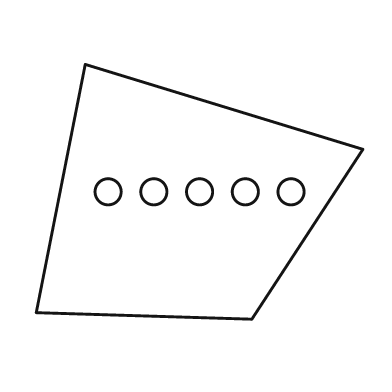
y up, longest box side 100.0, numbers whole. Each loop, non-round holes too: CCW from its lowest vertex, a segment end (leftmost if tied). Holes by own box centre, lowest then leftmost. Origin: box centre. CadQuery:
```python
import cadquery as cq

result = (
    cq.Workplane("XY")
    .moveTo(16.0, -39.0)
    .lineTo(50.0, 13.0)
    .lineTo(-35.0, 39.0)
    .lineTo(-50.0, -37.0)
    .close()
    .moveTo(-28.0, 0.0)
    .circle(4.0)
    .moveTo(-14.0, 0.0)
    .circle(4.0)
    .moveTo(0.0, 0.0)
    .circle(4.0)
    .moveTo(14.0, 0.0)
    .circle(4.0)
    .moveTo(28.0, 0.0)
    .circle(4.0)
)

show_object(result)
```